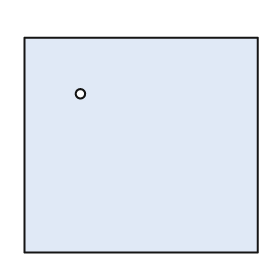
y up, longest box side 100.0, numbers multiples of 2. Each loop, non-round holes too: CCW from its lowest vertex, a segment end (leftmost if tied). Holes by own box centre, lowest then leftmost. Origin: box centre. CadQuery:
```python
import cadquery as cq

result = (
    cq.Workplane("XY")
    .moveTo(-50.0, -46.0)
    .lineTo(50.0, -46.0)
    .lineTo(50.0, 46.0)
    .lineTo(-50.0, 46.0)
    .close()
    .moveTo(-26.0, 22.0)
    .circle(2.0)
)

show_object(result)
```